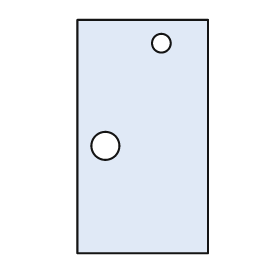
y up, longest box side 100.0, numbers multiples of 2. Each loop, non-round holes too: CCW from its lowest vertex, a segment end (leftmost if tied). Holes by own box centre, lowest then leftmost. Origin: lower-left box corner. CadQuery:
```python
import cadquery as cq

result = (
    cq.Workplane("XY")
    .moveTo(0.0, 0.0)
    .lineTo(56.0, 0.0)
    .lineTo(56.0, 100.0)
    .lineTo(0.0, 100.0)
    .close()
    .moveTo(12.0, 46.0)
    .circle(6.0)
    .moveTo(36.0, 90.0)
    .circle(4.0)
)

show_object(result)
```